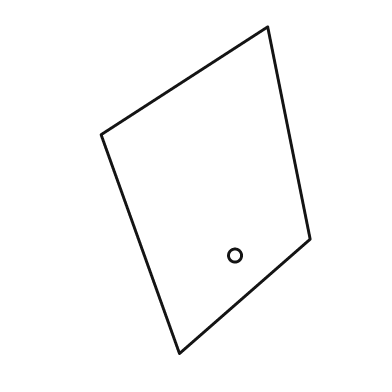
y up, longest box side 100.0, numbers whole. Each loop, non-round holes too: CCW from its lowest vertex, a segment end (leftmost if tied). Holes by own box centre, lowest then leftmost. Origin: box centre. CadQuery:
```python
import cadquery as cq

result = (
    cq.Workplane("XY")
    .moveTo(-8.0, -50.0)
    .lineTo(32.0, -15.0)
    .lineTo(19.0, 50.0)
    .lineTo(-32.0, 17.0)
    .close()
    .moveTo(9.0, -20.0)
    .circle(2.0)
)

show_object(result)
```